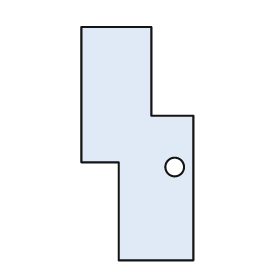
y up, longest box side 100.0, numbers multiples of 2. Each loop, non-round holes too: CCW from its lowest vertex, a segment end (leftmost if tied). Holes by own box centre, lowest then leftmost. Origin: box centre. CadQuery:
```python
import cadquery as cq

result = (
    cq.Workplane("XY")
    .moveTo(-8.0, -50.0)
    .lineTo(24.0, -50.0)
    .lineTo(24.0, 12.0)
    .lineTo(6.0, 12.0)
    .lineTo(6.0, 50.0)
    .lineTo(-24.0, 50.0)
    .lineTo(-24.0, -8.0)
    .lineTo(-8.0, -8.0)
    .close()
    .moveTo(16.0, -10.0)
    .circle(4.0)
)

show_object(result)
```